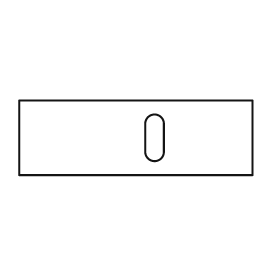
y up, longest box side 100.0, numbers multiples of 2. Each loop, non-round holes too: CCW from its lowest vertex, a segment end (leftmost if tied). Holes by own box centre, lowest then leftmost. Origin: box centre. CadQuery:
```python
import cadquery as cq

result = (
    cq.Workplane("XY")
    .moveTo(-50.0, -16.0)
    .lineTo(50.0, -16.0)
    .lineTo(50.0, 16.0)
    .lineTo(-50.0, 16.0)
    .close()
    .moveTo(4.0, -6.0)
    .threePointArc((8.0, -10.0), (12.0, -6.0))
    .lineTo(12.0, 6.0)
    .threePointArc((8.0, 10.0), (4.0, 6.0))
    .close()
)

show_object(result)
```